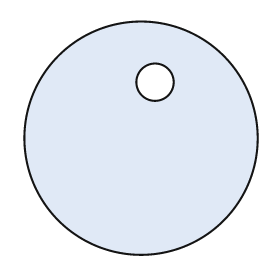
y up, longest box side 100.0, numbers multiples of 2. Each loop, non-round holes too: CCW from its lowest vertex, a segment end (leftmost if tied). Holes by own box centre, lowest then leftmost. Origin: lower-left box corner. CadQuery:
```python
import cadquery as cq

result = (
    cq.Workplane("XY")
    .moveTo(50.0, 50.0)
    .circle(50.0)
    .moveTo(56.0, 74.0)
    .circle(8.0)
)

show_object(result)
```